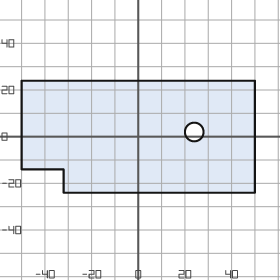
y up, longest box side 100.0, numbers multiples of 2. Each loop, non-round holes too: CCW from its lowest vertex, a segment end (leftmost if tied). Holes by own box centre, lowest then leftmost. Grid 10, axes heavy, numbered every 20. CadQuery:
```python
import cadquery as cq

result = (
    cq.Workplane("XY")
    .moveTo(-32.0, -24.0)
    .lineTo(50.0, -24.0)
    .lineTo(50.0, 24.0)
    .lineTo(-50.0, 24.0)
    .lineTo(-50.0, -14.0)
    .lineTo(-32.0, -14.0)
    .close()
    .moveTo(24.0, 2.0)
    .circle(4.0)
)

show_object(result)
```